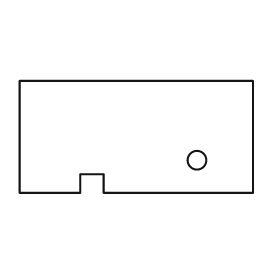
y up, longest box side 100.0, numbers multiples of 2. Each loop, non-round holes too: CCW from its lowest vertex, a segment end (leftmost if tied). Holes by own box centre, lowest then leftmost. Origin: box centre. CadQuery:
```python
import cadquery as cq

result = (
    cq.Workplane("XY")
    .moveTo(-50.0, -24.0)
    .lineTo(-24.0, -24.0)
    .lineTo(-24.0, -16.0)
    .lineTo(-14.0, -16.0)
    .lineTo(-14.0, -24.0)
    .lineTo(50.0, -24.0)
    .lineTo(50.0, 24.0)
    .lineTo(-50.0, 24.0)
    .close()
    .moveTo(26.0, -10.0)
    .circle(4.0)
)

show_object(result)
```